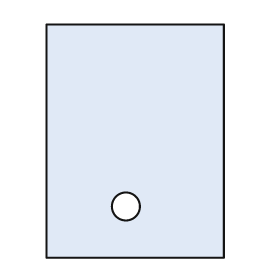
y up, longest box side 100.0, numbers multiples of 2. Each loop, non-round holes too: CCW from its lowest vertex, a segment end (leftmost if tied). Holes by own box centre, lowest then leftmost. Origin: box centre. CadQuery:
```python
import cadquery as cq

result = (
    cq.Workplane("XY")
    .moveTo(-38.0, -50.0)
    .lineTo(38.0, -50.0)
    .lineTo(38.0, 50.0)
    .lineTo(-38.0, 50.0)
    .close()
    .moveTo(-4.0, -28.0)
    .circle(6.0)
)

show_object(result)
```